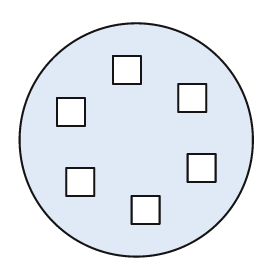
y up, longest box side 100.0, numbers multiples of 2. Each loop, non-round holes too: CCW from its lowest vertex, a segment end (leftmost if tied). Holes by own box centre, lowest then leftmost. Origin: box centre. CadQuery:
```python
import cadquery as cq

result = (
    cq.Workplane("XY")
    .moveTo(0.0, 0.0)
    .circle(50.0)
    .moveTo(-2.0, -36.0)
    .lineTo(10.0, -36.0)
    .lineTo(10.0, -24.0)
    .lineTo(-2.0, -24.0)
    .close()
    .moveTo(-30.0, -24.0)
    .lineTo(-18.0, -24.0)
    .lineTo(-18.0, -12.0)
    .lineTo(-30.0, -12.0)
    .close()
    .moveTo(22.0, -18.0)
    .lineTo(34.0, -18.0)
    .lineTo(34.0, -6.0)
    .lineTo(22.0, -6.0)
    .close()
    .moveTo(-34.0, 6.0)
    .lineTo(-22.0, 6.0)
    .lineTo(-22.0, 18.0)
    .lineTo(-34.0, 18.0)
    .close()
    .moveTo(18.0, 12.0)
    .lineTo(30.0, 12.0)
    .lineTo(30.0, 24.0)
    .lineTo(18.0, 24.0)
    .close()
    .moveTo(-10.0, 24.0)
    .lineTo(2.0, 24.0)
    .lineTo(2.0, 36.0)
    .lineTo(-10.0, 36.0)
    .close()
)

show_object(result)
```